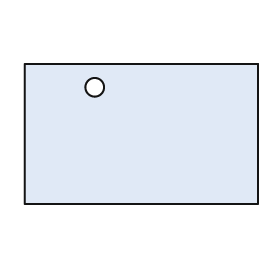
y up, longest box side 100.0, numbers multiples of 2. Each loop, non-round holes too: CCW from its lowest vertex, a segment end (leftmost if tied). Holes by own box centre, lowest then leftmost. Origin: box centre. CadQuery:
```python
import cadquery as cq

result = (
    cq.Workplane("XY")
    .moveTo(-50.0, -30.0)
    .lineTo(50.0, -30.0)
    .lineTo(50.0, 30.0)
    .lineTo(-50.0, 30.0)
    .close()
    .moveTo(-20.0, 20.0)
    .circle(4.0)
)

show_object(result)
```